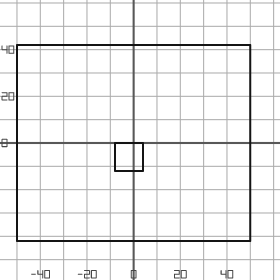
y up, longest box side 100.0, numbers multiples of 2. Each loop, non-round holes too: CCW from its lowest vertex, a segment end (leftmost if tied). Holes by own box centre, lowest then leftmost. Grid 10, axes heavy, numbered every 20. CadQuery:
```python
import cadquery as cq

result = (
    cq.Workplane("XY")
    .moveTo(-50.0, -42.0)
    .lineTo(50.0, -42.0)
    .lineTo(50.0, 42.0)
    .lineTo(-50.0, 42.0)
    .close()
    .moveTo(-8.0, -12.0)
    .lineTo(4.0, -12.0)
    .lineTo(4.0, 0.0)
    .lineTo(-8.0, 0.0)
    .close()
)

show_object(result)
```